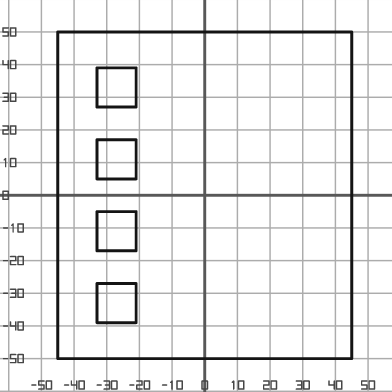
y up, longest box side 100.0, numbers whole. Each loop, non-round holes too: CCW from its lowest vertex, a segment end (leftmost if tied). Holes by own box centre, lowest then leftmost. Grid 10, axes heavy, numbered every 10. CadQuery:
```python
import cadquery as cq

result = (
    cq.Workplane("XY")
    .moveTo(-45.0, -50.0)
    .lineTo(45.0, -50.0)
    .lineTo(45.0, 50.0)
    .lineTo(-45.0, 50.0)
    .close()
    .moveTo(-33.0, -39.0)
    .lineTo(-21.0, -39.0)
    .lineTo(-21.0, -27.0)
    .lineTo(-33.0, -27.0)
    .close()
    .moveTo(-33.0, -17.0)
    .lineTo(-21.0, -17.0)
    .lineTo(-21.0, -5.0)
    .lineTo(-33.0, -5.0)
    .close()
    .moveTo(-33.0, 5.0)
    .lineTo(-21.0, 5.0)
    .lineTo(-21.0, 17.0)
    .lineTo(-33.0, 17.0)
    .close()
    .moveTo(-33.0, 27.0)
    .lineTo(-21.0, 27.0)
    .lineTo(-21.0, 39.0)
    .lineTo(-33.0, 39.0)
    .close()
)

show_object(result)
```